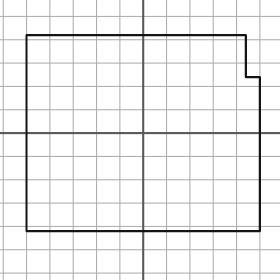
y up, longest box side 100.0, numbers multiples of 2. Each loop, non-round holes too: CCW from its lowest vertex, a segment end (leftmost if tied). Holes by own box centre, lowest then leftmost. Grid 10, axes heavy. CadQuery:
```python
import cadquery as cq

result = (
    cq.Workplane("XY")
    .moveTo(-50.0, -42.0)
    .lineTo(50.0, -42.0)
    .lineTo(50.0, 24.0)
    .lineTo(44.0, 24.0)
    .lineTo(44.0, 42.0)
    .lineTo(-50.0, 42.0)
    .close()
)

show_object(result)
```